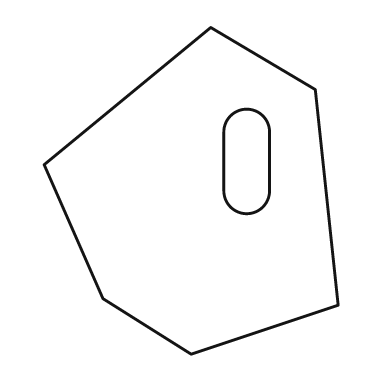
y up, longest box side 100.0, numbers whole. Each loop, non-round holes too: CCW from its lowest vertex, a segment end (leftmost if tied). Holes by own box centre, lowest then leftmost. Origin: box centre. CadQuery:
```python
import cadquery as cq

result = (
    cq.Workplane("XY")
    .moveTo(0.0, -50.0)
    .lineTo(45.0, -35.0)
    .lineTo(38.0, 31.0)
    .lineTo(6.0, 50.0)
    .lineTo(-45.0, 8.0)
    .lineTo(-27.0, -33.0)
    .close()
    .moveTo(10.0, 0.0)
    .threePointArc((17.0, -7.0), (24.0, 0.0))
    .lineTo(24.0, 18.0)
    .threePointArc((17.0, 25.0), (10.0, 18.0))
    .close()
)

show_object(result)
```